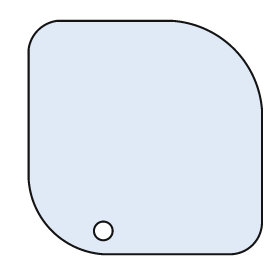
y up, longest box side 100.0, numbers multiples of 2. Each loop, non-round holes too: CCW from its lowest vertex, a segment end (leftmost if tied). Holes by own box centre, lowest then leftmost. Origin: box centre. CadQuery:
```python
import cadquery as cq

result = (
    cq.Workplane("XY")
    .moveTo(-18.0, -50.0)
    .lineTo(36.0, -50.0)
    .threePointArc((46.0, -46.0), (50.0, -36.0))
    .lineTo(50.0, 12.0)
    .threePointArc((38.0, 38.0), (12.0, 50.0))
    .lineTo(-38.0, 50.0)
    .threePointArc((-46.0, 46.0), (-50.0, 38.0))
    .lineTo(-50.0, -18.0)
    .threePointArc((-40.0, -40.0), (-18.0, -50.0))
    .close()
    .moveTo(-18.0, -40.0)
    .circle(4.0)
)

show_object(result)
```